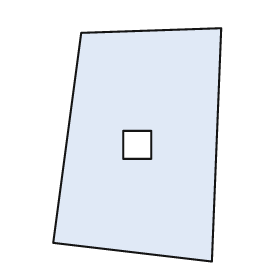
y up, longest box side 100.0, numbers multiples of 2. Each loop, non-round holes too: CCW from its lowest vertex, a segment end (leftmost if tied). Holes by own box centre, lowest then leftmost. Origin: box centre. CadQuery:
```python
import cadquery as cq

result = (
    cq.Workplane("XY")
    .moveTo(32.0, -50.0)
    .lineTo(36.0, 50.0)
    .lineTo(-24.0, 48.0)
    .lineTo(-36.0, -42.0)
    .close()
    .moveTo(-6.0, -6.0)
    .lineTo(6.0, -6.0)
    .lineTo(6.0, 6.0)
    .lineTo(-6.0, 6.0)
    .close()
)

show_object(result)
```